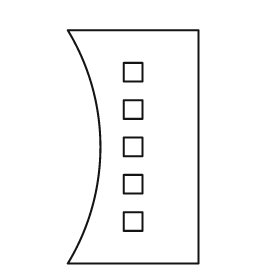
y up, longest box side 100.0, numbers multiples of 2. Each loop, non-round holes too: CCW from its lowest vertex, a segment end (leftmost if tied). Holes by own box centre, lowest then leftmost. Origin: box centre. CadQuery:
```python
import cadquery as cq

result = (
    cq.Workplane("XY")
    .moveTo(-28.0, -50.0)
    .lineTo(28.0, -50.0)
    .lineTo(28.0, 50.0)
    .lineTo(-28.0, 50.0)
    .threePointArc((-14.0, 0.0), (-28.0, -50.0))
    .close()
    .moveTo(-4.0, -36.0)
    .lineTo(4.0, -36.0)
    .lineTo(4.0, -28.0)
    .lineTo(-4.0, -28.0)
    .close()
    .moveTo(-4.0, -20.0)
    .lineTo(4.0, -20.0)
    .lineTo(4.0, -12.0)
    .lineTo(-4.0, -12.0)
    .close()
    .moveTo(-4.0, -4.0)
    .lineTo(4.0, -4.0)
    .lineTo(4.0, 4.0)
    .lineTo(-4.0, 4.0)
    .close()
    .moveTo(-4.0, 12.0)
    .lineTo(4.0, 12.0)
    .lineTo(4.0, 20.0)
    .lineTo(-4.0, 20.0)
    .close()
    .moveTo(-4.0, 28.0)
    .lineTo(4.0, 28.0)
    .lineTo(4.0, 36.0)
    .lineTo(-4.0, 36.0)
    .close()
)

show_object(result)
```